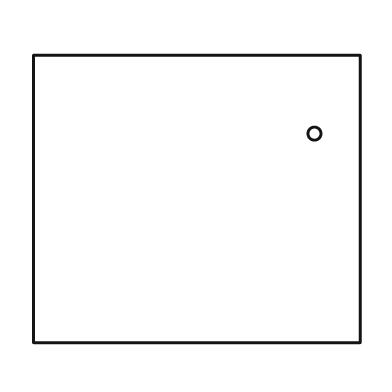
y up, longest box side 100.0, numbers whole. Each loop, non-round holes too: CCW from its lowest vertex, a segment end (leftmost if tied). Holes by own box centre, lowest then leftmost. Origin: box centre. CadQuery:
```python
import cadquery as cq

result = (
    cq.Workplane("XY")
    .moveTo(-50.0, -44.0)
    .lineTo(50.0, -44.0)
    .lineTo(50.0, 44.0)
    .lineTo(-50.0, 44.0)
    .close()
    .moveTo(36.0, 20.0)
    .circle(2.0)
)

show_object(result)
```